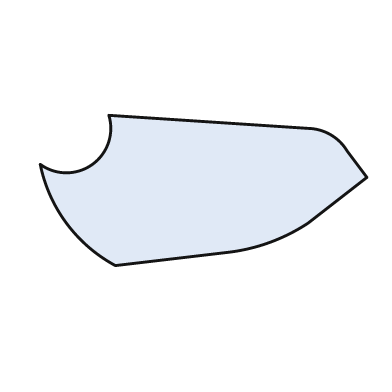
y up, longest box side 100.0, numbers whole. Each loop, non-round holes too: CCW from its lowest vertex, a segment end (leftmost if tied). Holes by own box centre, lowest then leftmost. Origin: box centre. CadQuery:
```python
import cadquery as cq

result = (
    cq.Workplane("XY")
    .moveTo(-27.0, -23.0)
    .lineTo(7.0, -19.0)
    .threePointArc((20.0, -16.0), (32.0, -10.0))
    .lineTo(50.0, 4.0)
    .lineTo(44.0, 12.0)
    .threePointArc((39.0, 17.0), (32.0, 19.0))
    .lineTo(-29.0, 23.0)
    .threePointArc((-34.0, 8.0), (-50.0, 8.0))
    .threePointArc((-42.0, -10.0), (-27.0, -23.0))
    .close()
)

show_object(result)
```